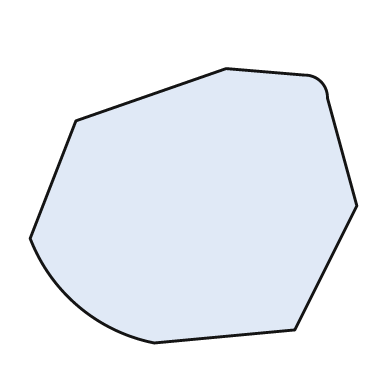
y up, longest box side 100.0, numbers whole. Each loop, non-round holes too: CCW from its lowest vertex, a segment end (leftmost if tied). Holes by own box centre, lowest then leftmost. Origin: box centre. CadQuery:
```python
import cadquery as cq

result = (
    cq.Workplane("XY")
    .moveTo(-12.0, -42.0)
    .lineTo(31.0, -38.0)
    .lineTo(50.0, 0.0)
    .lineTo(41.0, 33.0)
    .threePointArc((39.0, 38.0), (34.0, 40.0))
    .lineTo(10.0, 42.0)
    .lineTo(-36.0, 26.0)
    .lineTo(-50.0, -10.0)
    .threePointArc((-35.0, -31.0), (-12.0, -42.0))
    .close()
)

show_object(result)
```